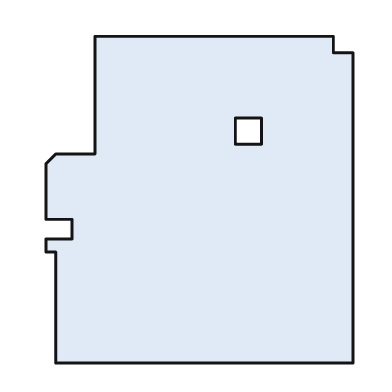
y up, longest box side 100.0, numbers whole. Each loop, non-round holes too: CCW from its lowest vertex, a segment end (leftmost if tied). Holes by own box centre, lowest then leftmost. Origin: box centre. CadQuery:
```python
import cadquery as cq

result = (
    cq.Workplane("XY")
    .moveTo(-44.0, -50.0)
    .lineTo(47.0, -50.0)
    .lineTo(47.0, 45.0)
    .lineTo(41.0, 45.0)
    .lineTo(41.0, 50.0)
    .lineTo(-32.0, 50.0)
    .lineTo(-32.0, 14.0)
    .lineTo(-44.0, 14.0)
    .lineTo(-47.0, 11.0)
    .lineTo(-47.0, -6.0)
    .lineTo(-39.0, -6.0)
    .lineTo(-39.0, -12.0)
    .lineTo(-47.0, -12.0)
    .lineTo(-47.0, -16.0)
    .lineTo(-44.0, -16.0)
    .close()
    .moveTo(11.0, 17.0)
    .lineTo(19.0, 17.0)
    .lineTo(19.0, 25.0)
    .lineTo(11.0, 25.0)
    .close()
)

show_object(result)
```